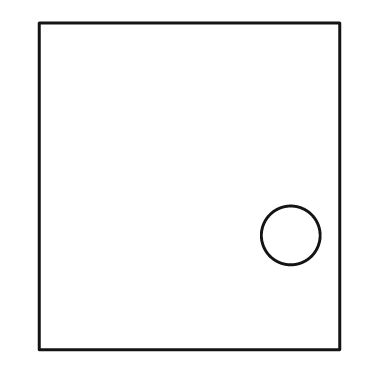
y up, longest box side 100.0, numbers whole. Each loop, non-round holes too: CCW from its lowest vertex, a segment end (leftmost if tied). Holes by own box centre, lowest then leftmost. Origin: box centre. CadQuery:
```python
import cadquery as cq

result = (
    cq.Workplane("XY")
    .moveTo(-46.0, -50.0)
    .lineTo(46.0, -50.0)
    .lineTo(46.0, 50.0)
    .lineTo(-46.0, 50.0)
    .close()
    .moveTo(31.0, -15.0)
    .circle(9.0)
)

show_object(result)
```